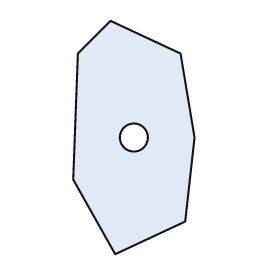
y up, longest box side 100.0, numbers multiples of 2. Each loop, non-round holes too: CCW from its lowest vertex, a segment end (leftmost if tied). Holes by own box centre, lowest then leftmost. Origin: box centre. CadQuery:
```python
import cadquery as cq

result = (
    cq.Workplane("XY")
    .moveTo(-8.0, -50.0)
    .lineTo(22.0, -36.0)
    .lineTo(26.0, 0.0)
    .lineTo(20.0, 36.0)
    .lineTo(-10.0, 50.0)
    .lineTo(-24.0, 36.0)
    .lineTo(-26.0, -18.0)
    .close()
    .moveTo(0.0, 0.0)
    .circle(6.0)
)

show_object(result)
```